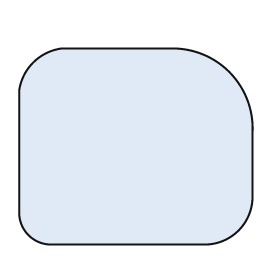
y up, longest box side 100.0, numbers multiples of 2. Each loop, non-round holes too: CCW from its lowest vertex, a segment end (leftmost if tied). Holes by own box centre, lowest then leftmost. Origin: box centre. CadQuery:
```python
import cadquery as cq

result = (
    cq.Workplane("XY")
    .moveTo(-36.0, -42.0)
    .lineTo(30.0, -42.0)
    .threePointArc((44.0, -36.0), (50.0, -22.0))
    .lineTo(50.0, 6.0)
    .threePointArc((40.0, 32.0), (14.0, 42.0))
    .lineTo(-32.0, 42.0)
    .threePointArc((-44.0, 36.0), (-50.0, 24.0))
    .lineTo(-50.0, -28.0)
    .threePointArc((-46.0, -38.0), (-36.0, -42.0))
    .close()
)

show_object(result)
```